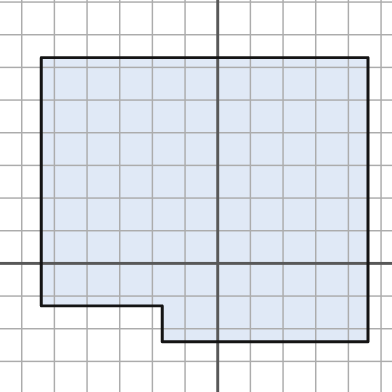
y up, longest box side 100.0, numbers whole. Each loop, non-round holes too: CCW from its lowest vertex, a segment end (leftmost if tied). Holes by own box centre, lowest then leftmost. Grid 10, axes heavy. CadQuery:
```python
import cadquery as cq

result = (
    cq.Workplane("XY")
    .moveTo(-17.0, -24.0)
    .lineTo(46.0, -24.0)
    .lineTo(46.0, 63.0)
    .lineTo(-54.0, 63.0)
    .lineTo(-54.0, -13.0)
    .lineTo(-17.0, -13.0)
    .close()
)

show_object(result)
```